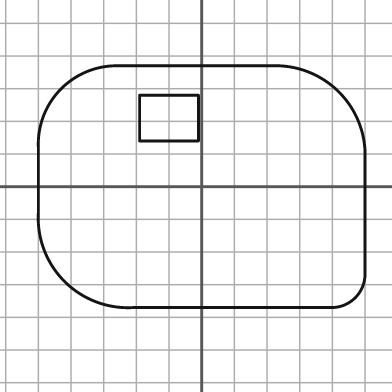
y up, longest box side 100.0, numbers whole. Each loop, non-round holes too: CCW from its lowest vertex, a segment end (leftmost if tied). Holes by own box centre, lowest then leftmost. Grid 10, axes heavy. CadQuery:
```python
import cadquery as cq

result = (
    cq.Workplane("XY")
    .moveTo(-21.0, -37.0)
    .lineTo(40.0, -37.0)
    .threePointArc((47.0, -34.0), (50.0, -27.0))
    .lineTo(50.0, 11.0)
    .threePointArc((42.0, 29.0), (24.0, 37.0))
    .lineTo(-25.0, 37.0)
    .threePointArc((-43.0, 30.0), (-50.0, 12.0))
    .lineTo(-50.0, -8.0)
    .threePointArc((-42.0, -29.0), (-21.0, -37.0))
    .close()
    .moveTo(-19.0, 14.0)
    .lineTo(-1.0, 14.0)
    .lineTo(-1.0, 28.0)
    .lineTo(-19.0, 28.0)
    .close()
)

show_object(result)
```